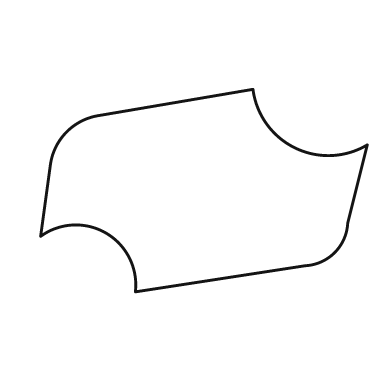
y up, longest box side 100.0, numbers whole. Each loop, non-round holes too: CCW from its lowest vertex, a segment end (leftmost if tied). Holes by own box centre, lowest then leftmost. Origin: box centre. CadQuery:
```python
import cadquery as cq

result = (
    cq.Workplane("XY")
    .moveTo(-21.0, -31.0)
    .lineTo(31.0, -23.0)
    .threePointArc((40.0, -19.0), (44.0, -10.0))
    .lineTo(50.0, 14.0)
    .threePointArc((28.0, 13.0), (15.0, 31.0))
    .lineTo(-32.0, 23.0)
    .threePointArc((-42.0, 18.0), (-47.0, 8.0))
    .lineTo(-50.0, -14.0)
    .threePointArc((-30.0, -13.0), (-21.0, -31.0))
    .close()
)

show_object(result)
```